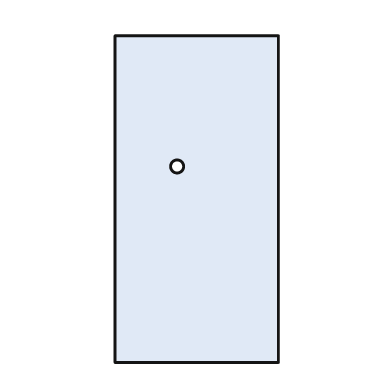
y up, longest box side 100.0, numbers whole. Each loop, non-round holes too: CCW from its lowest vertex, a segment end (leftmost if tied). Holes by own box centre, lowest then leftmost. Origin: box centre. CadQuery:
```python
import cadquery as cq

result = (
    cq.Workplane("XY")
    .moveTo(-25.0, -50.0)
    .lineTo(25.0, -50.0)
    .lineTo(25.0, 50.0)
    .lineTo(-25.0, 50.0)
    .close()
    .moveTo(-6.0, 10.0)
    .circle(2.0)
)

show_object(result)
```